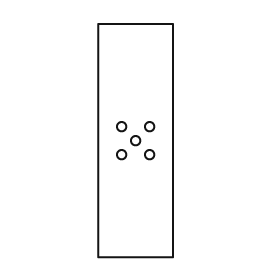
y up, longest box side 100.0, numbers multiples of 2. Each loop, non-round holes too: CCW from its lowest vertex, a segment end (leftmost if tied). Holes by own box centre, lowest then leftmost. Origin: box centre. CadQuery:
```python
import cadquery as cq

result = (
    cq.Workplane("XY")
    .moveTo(-16.0, -50.0)
    .lineTo(16.0, -50.0)
    .lineTo(16.0, 50.0)
    .lineTo(-16.0, 50.0)
    .close()
    .moveTo(-6.0, -6.0)
    .circle(2.0)
    .moveTo(6.0, -6.0)
    .circle(2.0)
    .moveTo(0.0, 0.0)
    .circle(2.0)
    .moveTo(-6.0, 6.0)
    .circle(2.0)
    .moveTo(6.0, 6.0)
    .circle(2.0)
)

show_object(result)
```